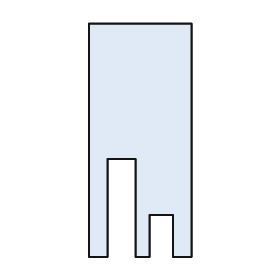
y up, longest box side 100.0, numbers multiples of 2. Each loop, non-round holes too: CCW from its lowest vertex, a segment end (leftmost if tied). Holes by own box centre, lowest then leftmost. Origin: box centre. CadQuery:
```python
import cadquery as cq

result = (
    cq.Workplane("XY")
    .moveTo(-22.0, -50.0)
    .lineTo(-14.0, -50.0)
    .lineTo(-14.0, -8.0)
    .lineTo(-2.0, -8.0)
    .lineTo(-2.0, -50.0)
    .lineTo(4.0, -50.0)
    .lineTo(4.0, -32.0)
    .lineTo(14.0, -32.0)
    .lineTo(14.0, -50.0)
    .lineTo(22.0, -50.0)
    .lineTo(22.0, 50.0)
    .lineTo(-22.0, 50.0)
    .close()
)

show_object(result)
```